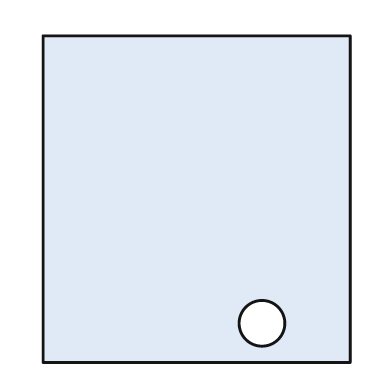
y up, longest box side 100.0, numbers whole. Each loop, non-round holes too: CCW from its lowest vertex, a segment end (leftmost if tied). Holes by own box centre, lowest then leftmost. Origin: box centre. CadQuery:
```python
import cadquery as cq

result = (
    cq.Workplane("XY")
    .moveTo(-47.0, -50.0)
    .lineTo(47.0, -50.0)
    .lineTo(47.0, 50.0)
    .lineTo(-47.0, 50.0)
    .close()
    .moveTo(20.0, -38.0)
    .circle(7.0)
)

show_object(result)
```